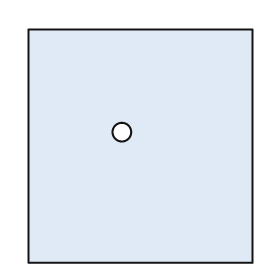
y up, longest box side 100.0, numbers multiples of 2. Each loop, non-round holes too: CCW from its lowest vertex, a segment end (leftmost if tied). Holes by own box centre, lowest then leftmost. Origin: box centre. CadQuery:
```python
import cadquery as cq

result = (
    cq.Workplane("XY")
    .moveTo(-48.0, -50.0)
    .lineTo(48.0, -50.0)
    .lineTo(48.0, 50.0)
    .lineTo(-48.0, 50.0)
    .close()
    .moveTo(-8.0, 6.0)
    .circle(4.0)
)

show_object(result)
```